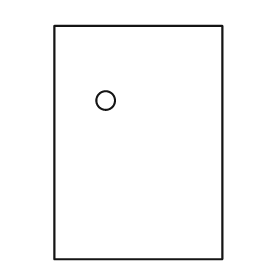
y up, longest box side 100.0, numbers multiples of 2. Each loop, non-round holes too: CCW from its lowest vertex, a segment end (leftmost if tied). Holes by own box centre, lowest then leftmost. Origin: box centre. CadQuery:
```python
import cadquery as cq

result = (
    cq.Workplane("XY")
    .moveTo(-36.0, -50.0)
    .lineTo(36.0, -50.0)
    .lineTo(36.0, 50.0)
    .lineTo(-36.0, 50.0)
    .close()
    .moveTo(-14.0, 18.0)
    .circle(4.0)
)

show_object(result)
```